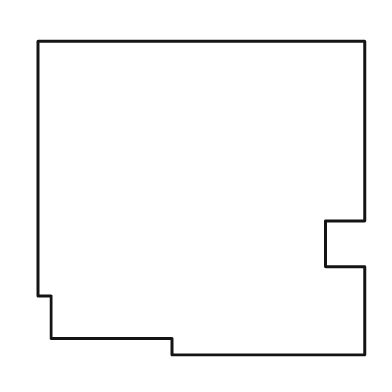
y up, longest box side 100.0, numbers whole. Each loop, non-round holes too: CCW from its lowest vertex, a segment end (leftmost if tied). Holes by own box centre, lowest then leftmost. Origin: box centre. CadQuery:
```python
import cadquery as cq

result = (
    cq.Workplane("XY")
    .moveTo(-9.0, -48.0)
    .lineTo(50.0, -48.0)
    .lineTo(50.0, -21.0)
    .lineTo(38.0, -21.0)
    .lineTo(38.0, -7.0)
    .lineTo(50.0, -7.0)
    .lineTo(50.0, 48.0)
    .lineTo(-50.0, 48.0)
    .lineTo(-50.0, -30.0)
    .lineTo(-46.0, -30.0)
    .lineTo(-46.0, -43.0)
    .lineTo(-9.0, -43.0)
    .close()
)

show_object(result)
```